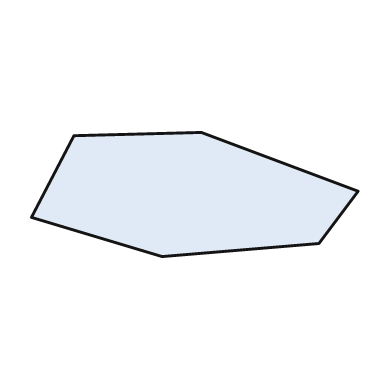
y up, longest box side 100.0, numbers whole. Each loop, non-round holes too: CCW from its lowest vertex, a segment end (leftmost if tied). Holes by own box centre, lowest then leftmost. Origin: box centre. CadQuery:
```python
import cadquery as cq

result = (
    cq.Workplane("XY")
    .moveTo(-10.0, -19.0)
    .lineTo(38.0, -15.0)
    .lineTo(50.0, 1.0)
    .lineTo(2.0, 19.0)
    .lineTo(-37.0, 18.0)
    .lineTo(-50.0, -7.0)
    .close()
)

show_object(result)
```